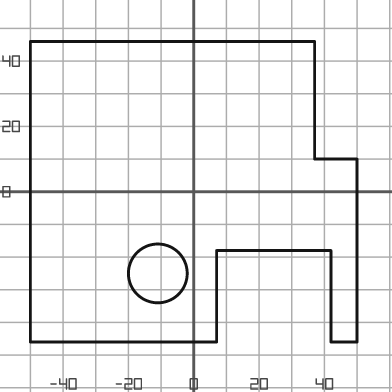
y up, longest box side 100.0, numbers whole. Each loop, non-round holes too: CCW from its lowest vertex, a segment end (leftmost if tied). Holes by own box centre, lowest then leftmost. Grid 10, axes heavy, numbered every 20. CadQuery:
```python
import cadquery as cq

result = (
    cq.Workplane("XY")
    .moveTo(-50.0, -46.0)
    .lineTo(7.0, -46.0)
    .lineTo(7.0, -18.0)
    .lineTo(42.0, -18.0)
    .lineTo(42.0, -46.0)
    .lineTo(50.0, -46.0)
    .lineTo(50.0, 10.0)
    .lineTo(37.0, 10.0)
    .lineTo(37.0, 46.0)
    .lineTo(-50.0, 46.0)
    .close()
    .moveTo(-11.0, -25.0)
    .circle(9.0)
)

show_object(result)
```